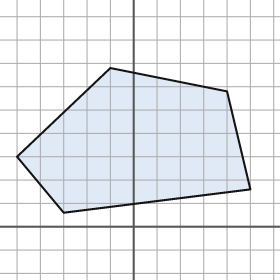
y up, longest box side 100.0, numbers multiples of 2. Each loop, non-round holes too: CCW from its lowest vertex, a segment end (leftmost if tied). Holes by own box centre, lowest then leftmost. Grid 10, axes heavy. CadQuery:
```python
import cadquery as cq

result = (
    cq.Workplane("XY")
    .moveTo(-30.0, 6.0)
    .lineTo(50.0, 16.0)
    .lineTo(40.0, 58.0)
    .lineTo(-10.0, 68.0)
    .lineTo(-50.0, 30.0)
    .close()
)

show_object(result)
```